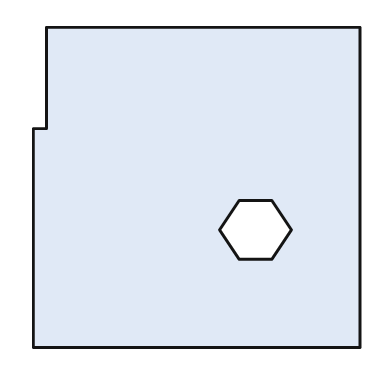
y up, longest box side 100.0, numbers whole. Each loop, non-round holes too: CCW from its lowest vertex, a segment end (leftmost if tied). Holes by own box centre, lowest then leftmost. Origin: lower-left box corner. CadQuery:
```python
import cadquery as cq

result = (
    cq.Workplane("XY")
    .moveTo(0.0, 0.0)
    .lineTo(100.0, 0.0)
    .lineTo(100.0, 98.0)
    .lineTo(4.0, 98.0)
    .lineTo(4.0, 67.0)
    .lineTo(0.0, 67.0)
    .close()
    .moveTo(63.0, 27.0)
    .lineTo(73.0, 27.0)
    .lineTo(79.0, 36.0)
    .lineTo(73.0, 45.0)
    .lineTo(63.0, 45.0)
    .lineTo(57.0, 36.0)
    .close()
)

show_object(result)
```